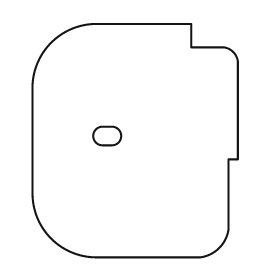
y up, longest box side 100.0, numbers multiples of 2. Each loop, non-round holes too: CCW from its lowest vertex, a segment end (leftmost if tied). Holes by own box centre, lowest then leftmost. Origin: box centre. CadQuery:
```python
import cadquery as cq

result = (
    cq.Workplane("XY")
    .moveTo(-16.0, -50.0)
    .lineTo(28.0, -50.0)
    .threePointArc((36.0, -46.0), (40.0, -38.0))
    .lineTo(40.0, -8.0)
    .lineTo(44.0, -8.0)
    .lineTo(44.0, 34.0)
    .threePointArc((42.0, 38.0), (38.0, 40.0))
    .lineTo(24.0, 40.0)
    .lineTo(24.0, 50.0)
    .lineTo(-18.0, 50.0)
    .threePointArc((-36.0, 42.0), (-44.0, 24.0))
    .lineTo(-44.0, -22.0)
    .threePointArc((-36.0, -42.0), (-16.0, -50.0))
    .close()
    .moveTo(-14.0, -2.0)
    .lineTo(-10.0, -2.0)
    .threePointArc((-6.0, 2.0), (-10.0, 6.0))
    .lineTo(-14.0, 6.0)
    .threePointArc((-18.0, 2.0), (-14.0, -2.0))
    .close()
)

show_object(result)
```